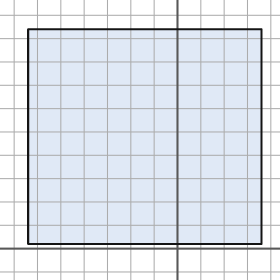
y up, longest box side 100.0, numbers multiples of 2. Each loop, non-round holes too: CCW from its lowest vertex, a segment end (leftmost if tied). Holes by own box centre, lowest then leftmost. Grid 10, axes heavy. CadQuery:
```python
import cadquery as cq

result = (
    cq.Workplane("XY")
    .moveTo(-64.0, 2.0)
    .lineTo(36.0, 2.0)
    .lineTo(36.0, 94.0)
    .lineTo(-64.0, 94.0)
    .close()
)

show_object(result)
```